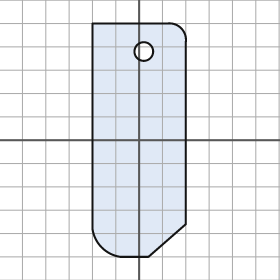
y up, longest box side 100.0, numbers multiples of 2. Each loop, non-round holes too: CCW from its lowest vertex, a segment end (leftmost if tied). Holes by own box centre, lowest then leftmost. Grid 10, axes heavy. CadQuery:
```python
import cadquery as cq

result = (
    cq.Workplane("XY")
    .moveTo(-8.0, -50.0)
    .lineTo(4.0, -50.0)
    .lineTo(20.0, -36.0)
    .lineTo(20.0, 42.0)
    .threePointArc((18.0, 48.0), (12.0, 50.0))
    .lineTo(-20.0, 50.0)
    .lineTo(-20.0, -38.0)
    .threePointArc((-16.0, -46.0), (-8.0, -50.0))
    .close()
    .moveTo(2.0, 38.0)
    .circle(4.0)
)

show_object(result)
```